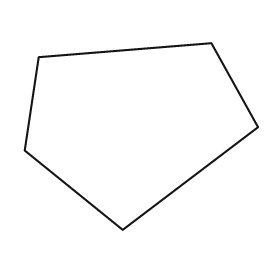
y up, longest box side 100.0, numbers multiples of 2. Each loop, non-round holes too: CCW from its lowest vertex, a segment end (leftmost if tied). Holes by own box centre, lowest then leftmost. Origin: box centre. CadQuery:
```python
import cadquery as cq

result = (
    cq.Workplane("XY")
    .moveTo(-8.0, -40.0)
    .lineTo(50.0, 4.0)
    .lineTo(30.0, 40.0)
    .lineTo(-44.0, 34.0)
    .lineTo(-50.0, -6.0)
    .close()
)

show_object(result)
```